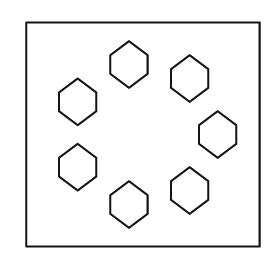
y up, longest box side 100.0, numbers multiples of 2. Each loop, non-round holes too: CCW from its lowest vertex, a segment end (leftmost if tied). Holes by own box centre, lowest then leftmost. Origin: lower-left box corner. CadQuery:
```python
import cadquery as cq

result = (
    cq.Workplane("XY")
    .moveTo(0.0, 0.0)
    .lineTo(100.0, 0.0)
    .lineTo(100.0, 96.0)
    .lineTo(0.0, 96.0)
    .close()
    .moveTo(44.0, 8.0)
    .lineTo(52.0, 14.0)
    .lineTo(52.0, 22.0)
    .lineTo(44.0, 28.0)
    .lineTo(36.0, 22.0)
    .lineTo(36.0, 14.0)
    .close()
    .moveTo(70.0, 14.0)
    .lineTo(78.0, 20.0)
    .lineTo(78.0, 28.0)
    .lineTo(70.0, 34.0)
    .lineTo(62.0, 28.0)
    .lineTo(62.0, 20.0)
    .close()
    .moveTo(22.0, 24.0)
    .lineTo(30.0, 30.0)
    .lineTo(30.0, 38.0)
    .lineTo(22.0, 44.0)
    .lineTo(14.0, 38.0)
    .lineTo(14.0, 30.0)
    .close()
    .moveTo(82.0, 38.0)
    .lineTo(90.0, 44.0)
    .lineTo(90.0, 52.0)
    .lineTo(82.0, 58.0)
    .lineTo(74.0, 52.0)
    .lineTo(74.0, 44.0)
    .close()
    .moveTo(22.0, 52.0)
    .lineTo(30.0, 58.0)
    .lineTo(30.0, 66.0)
    .lineTo(22.0, 72.0)
    .lineTo(14.0, 66.0)
    .lineTo(14.0, 58.0)
    .close()
    .moveTo(70.0, 62.0)
    .lineTo(78.0, 68.0)
    .lineTo(78.0, 76.0)
    .lineTo(70.0, 82.0)
    .lineTo(62.0, 76.0)
    .lineTo(62.0, 68.0)
    .close()
    .moveTo(44.0, 68.0)
    .lineTo(52.0, 74.0)
    .lineTo(52.0, 82.0)
    .lineTo(44.0, 88.0)
    .lineTo(36.0, 82.0)
    .lineTo(36.0, 74.0)
    .close()
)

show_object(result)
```